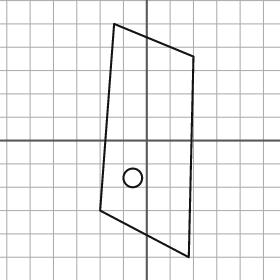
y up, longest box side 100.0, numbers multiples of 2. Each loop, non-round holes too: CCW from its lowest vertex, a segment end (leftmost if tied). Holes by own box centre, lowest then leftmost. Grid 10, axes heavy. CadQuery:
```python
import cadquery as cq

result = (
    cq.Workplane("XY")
    .moveTo(18.0, -50.0)
    .lineTo(20.0, 36.0)
    .lineTo(-14.0, 50.0)
    .lineTo(-20.0, -30.0)
    .close()
    .moveTo(-6.0, -16.0)
    .circle(4.0)
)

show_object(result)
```